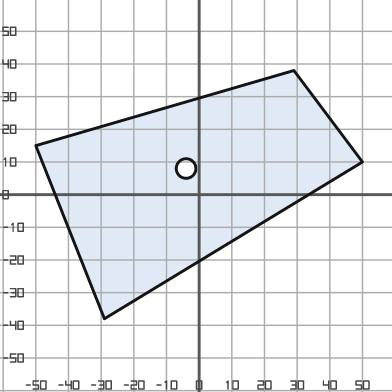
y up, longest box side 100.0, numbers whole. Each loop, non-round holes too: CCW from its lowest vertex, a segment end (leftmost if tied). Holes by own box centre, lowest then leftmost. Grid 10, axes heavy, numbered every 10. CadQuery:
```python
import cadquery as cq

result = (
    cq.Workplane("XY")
    .moveTo(-29.0, -38.0)
    .lineTo(50.0, 10.0)
    .lineTo(29.0, 38.0)
    .lineTo(-50.0, 15.0)
    .close()
    .moveTo(-4.0, 8.0)
    .circle(3.0)
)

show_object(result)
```